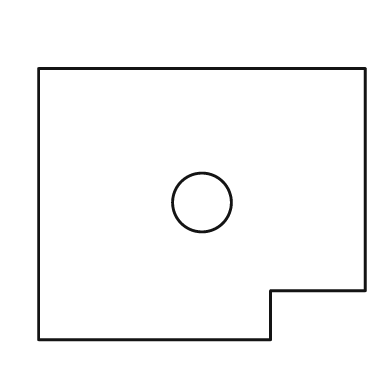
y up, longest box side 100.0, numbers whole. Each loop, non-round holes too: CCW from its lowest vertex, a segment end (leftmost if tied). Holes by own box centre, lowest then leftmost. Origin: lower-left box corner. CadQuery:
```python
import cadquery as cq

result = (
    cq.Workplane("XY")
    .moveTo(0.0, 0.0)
    .lineTo(71.0, 0.0)
    .lineTo(71.0, 15.0)
    .lineTo(100.0, 15.0)
    .lineTo(100.0, 83.0)
    .lineTo(0.0, 83.0)
    .close()
    .moveTo(50.0, 42.0)
    .circle(9.0)
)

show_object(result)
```